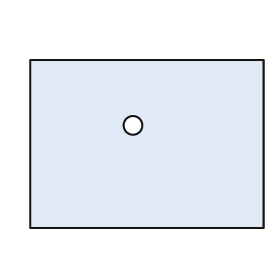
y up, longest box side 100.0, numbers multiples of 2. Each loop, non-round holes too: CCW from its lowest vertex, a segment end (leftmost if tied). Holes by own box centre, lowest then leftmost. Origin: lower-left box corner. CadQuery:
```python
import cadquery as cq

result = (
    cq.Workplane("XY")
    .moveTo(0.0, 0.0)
    .lineTo(100.0, 0.0)
    .lineTo(100.0, 72.0)
    .lineTo(0.0, 72.0)
    .close()
    .moveTo(44.0, 44.0)
    .circle(4.0)
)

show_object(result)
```